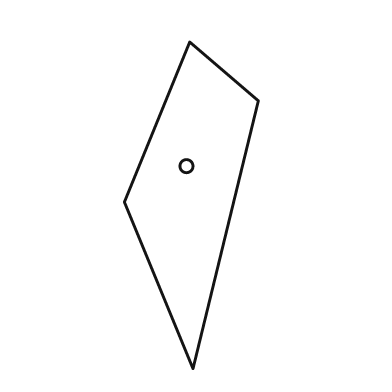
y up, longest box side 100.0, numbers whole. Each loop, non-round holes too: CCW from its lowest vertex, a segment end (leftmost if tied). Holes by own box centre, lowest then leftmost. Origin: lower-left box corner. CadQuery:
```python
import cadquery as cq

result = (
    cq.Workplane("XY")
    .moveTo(21.0, 0.0)
    .lineTo(41.0, 82.0)
    .lineTo(20.0, 100.0)
    .lineTo(0.0, 51.0)
    .close()
    .moveTo(19.0, 62.0)
    .circle(2.0)
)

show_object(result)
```